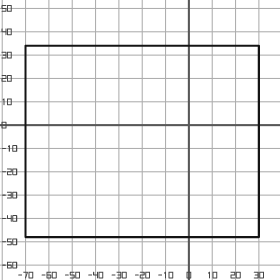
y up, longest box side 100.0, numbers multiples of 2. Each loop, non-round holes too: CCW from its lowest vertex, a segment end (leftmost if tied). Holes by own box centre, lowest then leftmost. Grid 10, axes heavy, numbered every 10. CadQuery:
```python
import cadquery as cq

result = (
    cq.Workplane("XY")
    .moveTo(-70.0, -48.0)
    .lineTo(30.0, -48.0)
    .lineTo(30.0, 34.0)
    .lineTo(-70.0, 34.0)
    .close()
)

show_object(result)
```